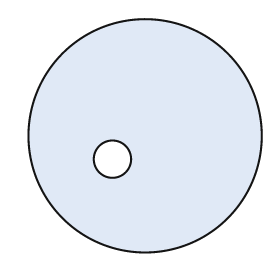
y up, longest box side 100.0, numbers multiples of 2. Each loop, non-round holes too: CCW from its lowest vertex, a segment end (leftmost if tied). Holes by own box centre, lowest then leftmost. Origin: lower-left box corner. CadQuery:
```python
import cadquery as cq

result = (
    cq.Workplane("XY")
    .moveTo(50.0, 50.0)
    .circle(50.0)
    .moveTo(36.0, 40.0)
    .circle(8.0)
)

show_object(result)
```